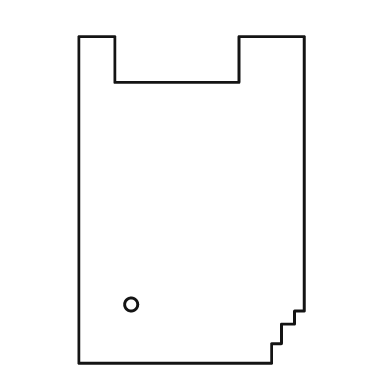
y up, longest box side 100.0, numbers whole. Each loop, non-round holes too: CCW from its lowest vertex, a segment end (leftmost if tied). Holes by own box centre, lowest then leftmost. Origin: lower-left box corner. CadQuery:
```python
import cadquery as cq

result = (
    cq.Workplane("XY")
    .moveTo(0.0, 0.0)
    .lineTo(59.0, 0.0)
    .lineTo(59.0, 6.0)
    .lineTo(62.0, 6.0)
    .lineTo(62.0, 12.0)
    .lineTo(66.0, 12.0)
    .lineTo(66.0, 16.0)
    .lineTo(69.0, 16.0)
    .lineTo(69.0, 100.0)
    .lineTo(49.0, 100.0)
    .lineTo(49.0, 86.0)
    .lineTo(11.0, 86.0)
    .lineTo(11.0, 100.0)
    .lineTo(0.0, 100.0)
    .close()
    .moveTo(16.0, 18.0)
    .circle(2.0)
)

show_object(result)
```